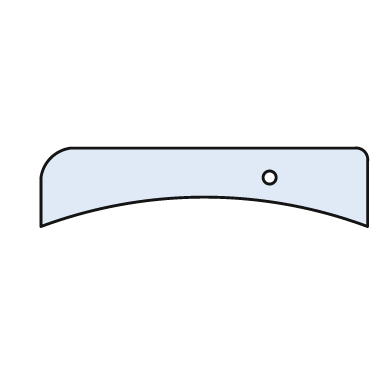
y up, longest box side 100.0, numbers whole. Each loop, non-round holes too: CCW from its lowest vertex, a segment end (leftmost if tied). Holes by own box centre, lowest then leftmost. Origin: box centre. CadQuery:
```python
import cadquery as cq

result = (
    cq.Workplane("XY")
    .moveTo(-50.0, -12.0)
    .threePointArc((0.0, -3.0), (50.0, -12.0))
    .lineTo(50.0, 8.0)
    .threePointArc((49.0, 11.0), (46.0, 12.0))
    .lineTo(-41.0, 12.0)
    .threePointArc((-47.0, 9.0), (-50.0, 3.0))
    .close()
    .moveTo(20.0, 3.0)
    .circle(2.0)
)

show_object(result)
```